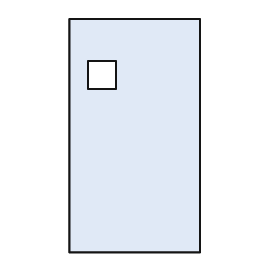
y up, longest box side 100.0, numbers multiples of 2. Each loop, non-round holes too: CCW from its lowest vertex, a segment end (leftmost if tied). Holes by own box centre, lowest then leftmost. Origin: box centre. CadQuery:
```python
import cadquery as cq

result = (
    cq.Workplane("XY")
    .moveTo(-28.0, -50.0)
    .lineTo(28.0, -50.0)
    .lineTo(28.0, 50.0)
    .lineTo(-28.0, 50.0)
    .close()
    .moveTo(-20.0, 20.0)
    .lineTo(-8.0, 20.0)
    .lineTo(-8.0, 32.0)
    .lineTo(-20.0, 32.0)
    .close()
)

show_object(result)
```